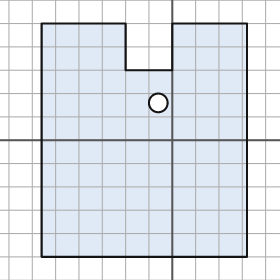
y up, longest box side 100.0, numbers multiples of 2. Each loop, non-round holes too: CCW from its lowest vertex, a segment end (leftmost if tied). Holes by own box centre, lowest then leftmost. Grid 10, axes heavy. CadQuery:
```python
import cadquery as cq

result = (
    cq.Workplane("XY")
    .moveTo(-56.0, -50.0)
    .lineTo(32.0, -50.0)
    .lineTo(32.0, 50.0)
    .lineTo(0.0, 50.0)
    .lineTo(0.0, 30.0)
    .lineTo(-20.0, 30.0)
    .lineTo(-20.0, 50.0)
    .lineTo(-56.0, 50.0)
    .close()
    .moveTo(-6.0, 16.0)
    .circle(4.0)
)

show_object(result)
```